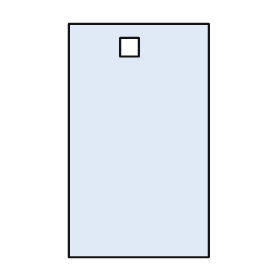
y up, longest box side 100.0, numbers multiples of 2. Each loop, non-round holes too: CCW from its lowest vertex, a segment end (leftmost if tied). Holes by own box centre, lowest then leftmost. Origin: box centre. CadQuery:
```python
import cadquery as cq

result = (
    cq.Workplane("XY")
    .moveTo(-30.0, -50.0)
    .lineTo(30.0, -50.0)
    .lineTo(30.0, 50.0)
    .lineTo(-30.0, 50.0)
    .close()
    .moveTo(-8.0, 36.0)
    .lineTo(0.0, 36.0)
    .lineTo(0.0, 44.0)
    .lineTo(-8.0, 44.0)
    .close()
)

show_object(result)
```